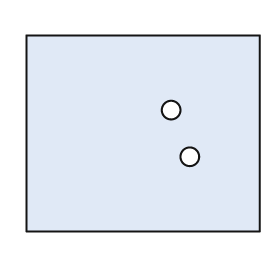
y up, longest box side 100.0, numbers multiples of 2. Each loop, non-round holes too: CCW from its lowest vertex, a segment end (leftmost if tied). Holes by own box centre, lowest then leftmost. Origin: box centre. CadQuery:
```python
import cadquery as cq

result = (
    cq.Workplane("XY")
    .moveTo(-50.0, -42.0)
    .lineTo(50.0, -42.0)
    .lineTo(50.0, 42.0)
    .lineTo(-50.0, 42.0)
    .close()
    .moveTo(20.0, -10.0)
    .circle(4.0)
    .moveTo(12.0, 10.0)
    .circle(4.0)
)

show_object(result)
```